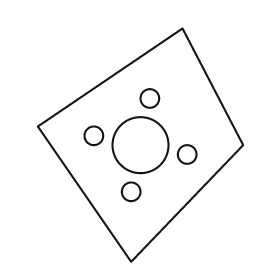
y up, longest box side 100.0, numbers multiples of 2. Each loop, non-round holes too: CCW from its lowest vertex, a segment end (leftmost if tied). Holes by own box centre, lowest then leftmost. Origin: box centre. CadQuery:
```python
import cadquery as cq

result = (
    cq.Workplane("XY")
    .moveTo(-4.0, -50.0)
    .lineTo(44.0, 0.0)
    .lineTo(18.0, 50.0)
    .lineTo(-44.0, 8.0)
    .close()
    .moveTo(-4.0, -20.0)
    .circle(4.0)
    .moveTo(20.0, -4.0)
    .circle(4.0)
    .moveTo(0.0, 0.0)
    .circle(12.0)
    .moveTo(-20.0, 4.0)
    .circle(4.0)
    .moveTo(4.0, 20.0)
    .circle(4.0)
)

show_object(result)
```